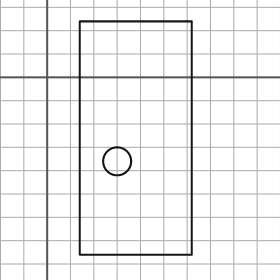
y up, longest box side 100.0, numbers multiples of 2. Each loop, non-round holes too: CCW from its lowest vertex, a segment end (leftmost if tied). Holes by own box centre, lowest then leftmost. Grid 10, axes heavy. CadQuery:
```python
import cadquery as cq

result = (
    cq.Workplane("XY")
    .moveTo(14.0, -76.0)
    .lineTo(62.0, -76.0)
    .lineTo(62.0, 24.0)
    .lineTo(14.0, 24.0)
    .close()
    .moveTo(30.0, -36.0)
    .circle(6.0)
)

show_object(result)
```